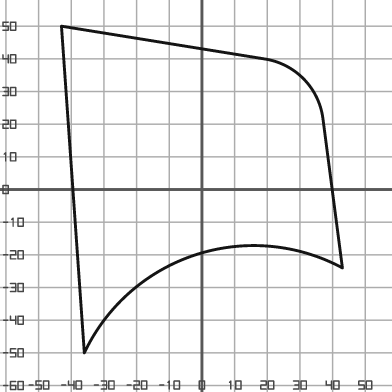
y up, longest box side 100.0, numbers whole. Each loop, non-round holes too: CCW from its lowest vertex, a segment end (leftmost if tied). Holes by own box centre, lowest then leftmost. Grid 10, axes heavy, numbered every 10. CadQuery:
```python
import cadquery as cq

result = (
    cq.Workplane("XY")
    .moveTo(-36.0, -50.0)
    .threePointArc((-2.0, -20.0), (43.0, -24.0))
    .lineTo(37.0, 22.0)
    .threePointArc((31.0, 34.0), (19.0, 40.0))
    .lineTo(-43.0, 50.0)
    .close()
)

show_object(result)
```